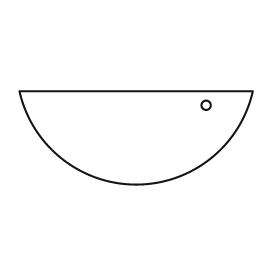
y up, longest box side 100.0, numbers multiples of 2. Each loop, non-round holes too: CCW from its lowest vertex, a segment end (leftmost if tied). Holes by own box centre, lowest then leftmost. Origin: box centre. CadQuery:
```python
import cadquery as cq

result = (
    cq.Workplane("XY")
    .moveTo(-50.0, 20.0)
    .threePointArc((0.0, -20.0), (50.0, 20.0))
    .close()
    .moveTo(30.0, 14.0)
    .circle(2.0)
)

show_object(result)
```